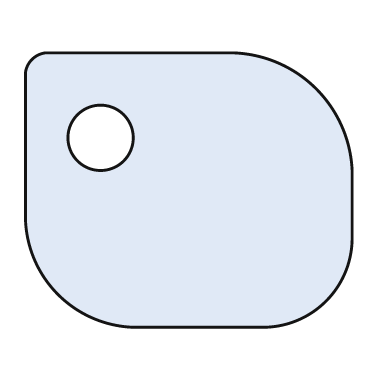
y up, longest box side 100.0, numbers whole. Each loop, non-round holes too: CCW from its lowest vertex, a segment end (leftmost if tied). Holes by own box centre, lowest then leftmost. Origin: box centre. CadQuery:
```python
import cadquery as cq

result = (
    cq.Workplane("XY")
    .moveTo(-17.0, -42.0)
    .lineTo(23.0, -42.0)
    .threePointArc((42.0, -34.0), (50.0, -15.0))
    .lineTo(50.0, 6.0)
    .threePointArc((39.0, 31.0), (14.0, 42.0))
    .lineTo(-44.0, 42.0)
    .threePointArc((-48.0, 40.0), (-50.0, 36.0))
    .lineTo(-50.0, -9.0)
    .threePointArc((-40.0, -32.0), (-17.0, -42.0))
    .close()
    .moveTo(-27.0, 16.0)
    .circle(10.0)
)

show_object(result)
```